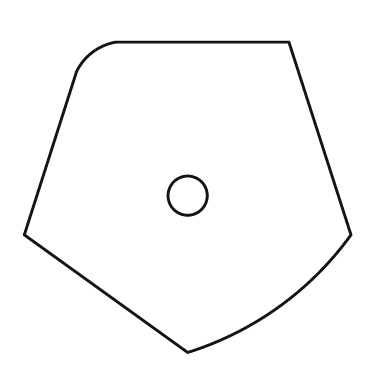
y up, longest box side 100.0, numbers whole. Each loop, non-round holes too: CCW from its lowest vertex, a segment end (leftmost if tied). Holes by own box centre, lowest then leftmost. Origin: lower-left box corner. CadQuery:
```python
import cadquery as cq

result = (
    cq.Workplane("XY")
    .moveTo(50.0, 0.0)
    .threePointArc((78.0, 14.0), (100.0, 36.0))
    .lineTo(81.0, 95.0)
    .lineTo(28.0, 95.0)
    .threePointArc((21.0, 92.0), (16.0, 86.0))
    .lineTo(0.0, 36.0)
    .close()
    .moveTo(50.0, 48.0)
    .circle(6.0)
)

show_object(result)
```